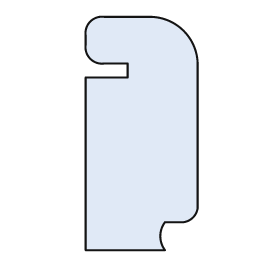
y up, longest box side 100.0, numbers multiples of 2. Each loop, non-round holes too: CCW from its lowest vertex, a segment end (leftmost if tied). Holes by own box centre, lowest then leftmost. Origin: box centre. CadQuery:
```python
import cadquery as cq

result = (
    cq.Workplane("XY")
    .moveTo(-24.0, -50.0)
    .lineTo(10.0, -50.0)
    .threePointArc((8.0, -44.0), (10.0, -38.0))
    .lineTo(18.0, -38.0)
    .threePointArc((22.0, -36.0), (24.0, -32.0))
    .lineTo(24.0, 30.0)
    .threePointArc((18.0, 44.0), (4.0, 50.0))
    .lineTo(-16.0, 50.0)
    .threePointArc((-22.0, 48.0), (-24.0, 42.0))
    .lineTo(-24.0, 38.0)
    .threePointArc((-22.0, 32.0), (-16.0, 30.0))
    .lineTo(-6.0, 30.0)
    .lineTo(-6.0, 24.0)
    .lineTo(-24.0, 24.0)
    .close()
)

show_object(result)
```